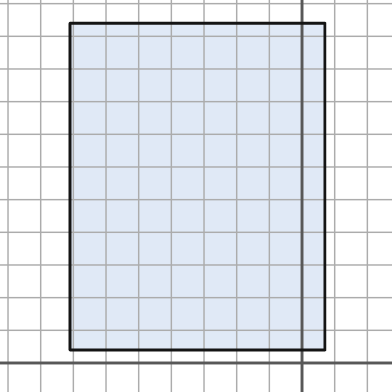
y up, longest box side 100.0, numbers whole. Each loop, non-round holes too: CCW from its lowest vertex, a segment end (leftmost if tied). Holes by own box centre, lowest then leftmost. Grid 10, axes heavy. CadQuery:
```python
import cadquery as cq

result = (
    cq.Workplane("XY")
    .moveTo(-71.0, 4.0)
    .lineTo(7.0, 4.0)
    .lineTo(7.0, 104.0)
    .lineTo(-71.0, 104.0)
    .close()
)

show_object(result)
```